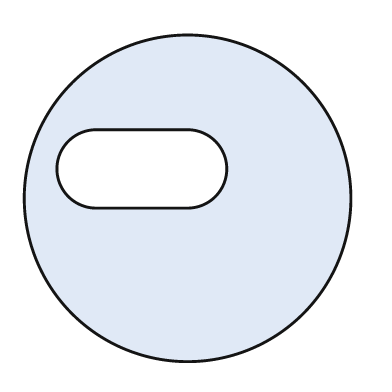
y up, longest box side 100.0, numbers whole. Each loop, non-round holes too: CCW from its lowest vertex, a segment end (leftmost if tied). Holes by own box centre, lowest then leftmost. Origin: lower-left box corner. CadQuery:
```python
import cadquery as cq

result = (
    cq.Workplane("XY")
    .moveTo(50.0, 50.0)
    .circle(50.0)
    .moveTo(22.0, 47.0)
    .lineTo(50.0, 47.0)
    .threePointArc((62.0, 59.0), (50.0, 71.0))
    .lineTo(22.0, 71.0)
    .threePointArc((10.0, 59.0), (22.0, 47.0))
    .close()
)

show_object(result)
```